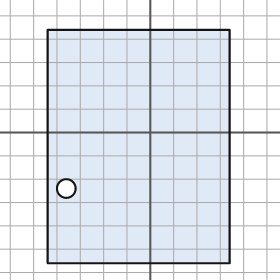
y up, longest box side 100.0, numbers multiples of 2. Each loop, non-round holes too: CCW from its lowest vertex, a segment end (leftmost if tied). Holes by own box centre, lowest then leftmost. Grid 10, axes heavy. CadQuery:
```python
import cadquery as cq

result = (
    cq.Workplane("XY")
    .moveTo(-44.0, -56.0)
    .lineTo(34.0, -56.0)
    .lineTo(34.0, 44.0)
    .lineTo(-44.0, 44.0)
    .close()
    .moveTo(-36.0, -24.0)
    .circle(4.0)
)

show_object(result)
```